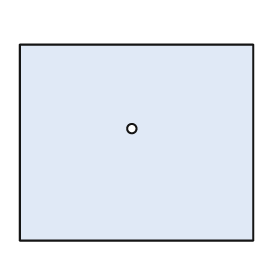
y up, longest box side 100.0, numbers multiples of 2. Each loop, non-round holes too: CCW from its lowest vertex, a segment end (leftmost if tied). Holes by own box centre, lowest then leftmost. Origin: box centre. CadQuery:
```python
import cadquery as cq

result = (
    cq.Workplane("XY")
    .moveTo(-50.0, -42.0)
    .lineTo(50.0, -42.0)
    .lineTo(50.0, 42.0)
    .lineTo(-50.0, 42.0)
    .close()
    .moveTo(-2.0, 6.0)
    .circle(2.0)
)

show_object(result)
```